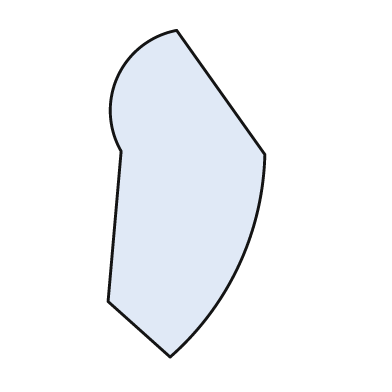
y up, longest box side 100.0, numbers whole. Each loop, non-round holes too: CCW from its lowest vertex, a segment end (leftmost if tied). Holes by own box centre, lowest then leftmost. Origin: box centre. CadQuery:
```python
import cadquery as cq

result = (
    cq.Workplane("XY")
    .moveTo(-5.0, -50.0)
    .threePointArc((16.0, -22.0), (24.0, 12.0))
    .lineTo(-3.0, 50.0)
    .threePointArc((-21.0, 36.0), (-20.0, 13.0))
    .lineTo(-24.0, -33.0)
    .close()
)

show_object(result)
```